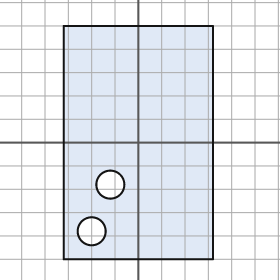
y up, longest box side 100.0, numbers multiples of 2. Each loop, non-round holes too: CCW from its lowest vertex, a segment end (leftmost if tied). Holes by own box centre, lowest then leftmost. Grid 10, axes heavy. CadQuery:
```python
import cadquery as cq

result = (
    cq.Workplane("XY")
    .moveTo(-32.0, -50.0)
    .lineTo(32.0, -50.0)
    .lineTo(32.0, 50.0)
    .lineTo(-32.0, 50.0)
    .close()
    .moveTo(-20.0, -38.0)
    .circle(6.0)
    .moveTo(-12.0, -18.0)
    .circle(6.0)
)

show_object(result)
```